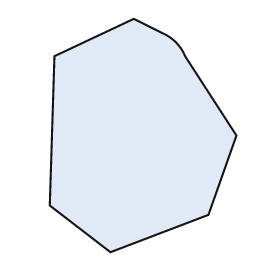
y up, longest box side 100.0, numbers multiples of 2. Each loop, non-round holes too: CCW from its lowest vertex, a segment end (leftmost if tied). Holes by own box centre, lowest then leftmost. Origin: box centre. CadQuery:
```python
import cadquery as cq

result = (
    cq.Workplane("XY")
    .moveTo(-14.0, -50.0)
    .lineTo(28.0, -34.0)
    .lineTo(40.0, 0.0)
    .lineTo(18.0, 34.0)
    .threePointArc((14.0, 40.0), (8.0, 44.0))
    .lineTo(-4.0, 50.0)
    .lineTo(-38.0, 34.0)
    .lineTo(-40.0, -30.0)
    .close()
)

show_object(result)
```